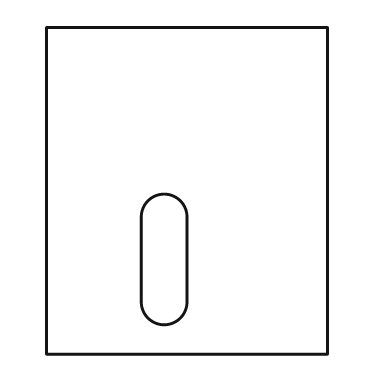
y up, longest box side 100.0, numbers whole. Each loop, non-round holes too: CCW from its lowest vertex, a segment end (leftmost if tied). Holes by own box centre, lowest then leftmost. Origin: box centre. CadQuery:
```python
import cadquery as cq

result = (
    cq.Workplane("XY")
    .moveTo(-43.0, -50.0)
    .lineTo(43.0, -50.0)
    .lineTo(43.0, 50.0)
    .lineTo(-43.0, 50.0)
    .close()
    .moveTo(-14.0, -34.0)
    .threePointArc((-7.0, -41.0), (0.0, -34.0))
    .lineTo(0.0, -8.0)
    .threePointArc((-7.0, -1.0), (-14.0, -8.0))
    .close()
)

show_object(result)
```